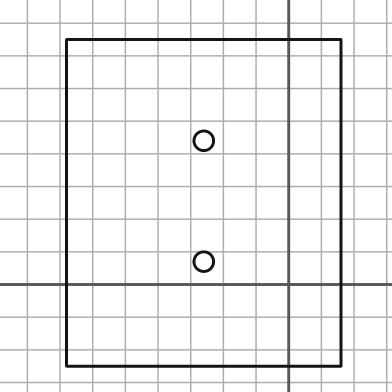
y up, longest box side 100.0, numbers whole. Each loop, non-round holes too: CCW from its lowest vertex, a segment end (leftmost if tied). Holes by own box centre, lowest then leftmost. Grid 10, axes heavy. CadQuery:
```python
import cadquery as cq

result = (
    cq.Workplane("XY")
    .moveTo(-68.0, -25.0)
    .lineTo(16.0, -25.0)
    .lineTo(16.0, 75.0)
    .lineTo(-68.0, 75.0)
    .close()
    .moveTo(-26.0, 7.0)
    .circle(3.0)
    .moveTo(-26.0, 44.0)
    .circle(3.0)
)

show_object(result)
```